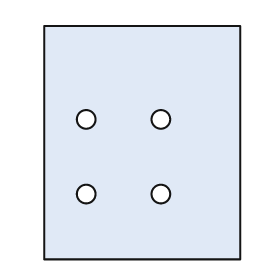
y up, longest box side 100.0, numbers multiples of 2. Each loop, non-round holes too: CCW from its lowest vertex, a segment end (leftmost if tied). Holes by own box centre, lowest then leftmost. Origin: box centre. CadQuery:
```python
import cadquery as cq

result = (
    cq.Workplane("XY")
    .moveTo(-42.0, -50.0)
    .lineTo(42.0, -50.0)
    .lineTo(42.0, 50.0)
    .lineTo(-42.0, 50.0)
    .close()
    .moveTo(-24.0, -22.0)
    .circle(4.0)
    .moveTo(8.0, -22.0)
    .circle(4.0)
    .moveTo(-24.0, 10.0)
    .circle(4.0)
    .moveTo(8.0, 10.0)
    .circle(4.0)
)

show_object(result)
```